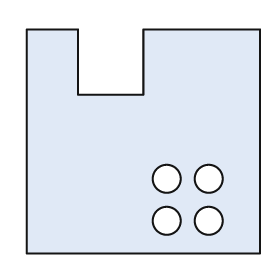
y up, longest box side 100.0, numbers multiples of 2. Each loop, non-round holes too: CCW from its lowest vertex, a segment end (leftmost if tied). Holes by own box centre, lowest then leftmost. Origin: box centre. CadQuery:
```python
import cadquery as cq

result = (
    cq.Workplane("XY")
    .moveTo(-50.0, -48.0)
    .lineTo(50.0, -48.0)
    .lineTo(50.0, 48.0)
    .lineTo(0.0, 48.0)
    .lineTo(0.0, 20.0)
    .lineTo(-28.0, 20.0)
    .lineTo(-28.0, 48.0)
    .lineTo(-50.0, 48.0)
    .close()
    .moveTo(10.0, -34.0)
    .circle(6.0)
    .moveTo(28.0, -34.0)
    .circle(6.0)
    .moveTo(10.0, -16.0)
    .circle(6.0)
    .moveTo(28.0, -16.0)
    .circle(6.0)
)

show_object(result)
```